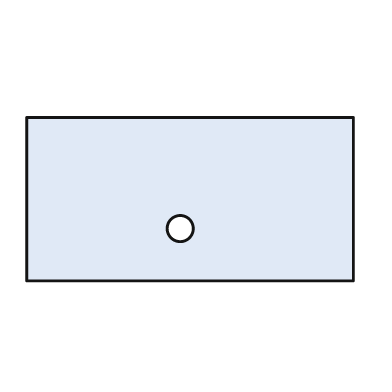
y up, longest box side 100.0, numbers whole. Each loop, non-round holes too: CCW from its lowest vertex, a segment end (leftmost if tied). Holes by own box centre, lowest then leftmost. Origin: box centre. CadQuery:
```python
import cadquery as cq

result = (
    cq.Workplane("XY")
    .moveTo(-50.0, -25.0)
    .lineTo(50.0, -25.0)
    .lineTo(50.0, 25.0)
    .lineTo(-50.0, 25.0)
    .close()
    .moveTo(-3.0, -9.0)
    .circle(4.0)
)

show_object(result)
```